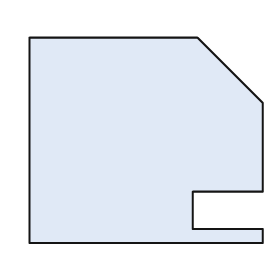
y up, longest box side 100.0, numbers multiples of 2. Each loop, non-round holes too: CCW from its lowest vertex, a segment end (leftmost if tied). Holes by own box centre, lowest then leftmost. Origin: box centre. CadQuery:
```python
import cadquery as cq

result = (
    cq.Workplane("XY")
    .moveTo(-50.0, -44.0)
    .lineTo(50.0, -44.0)
    .lineTo(50.0, -38.0)
    .lineTo(20.0, -38.0)
    .lineTo(20.0, -22.0)
    .lineTo(50.0, -22.0)
    .lineTo(50.0, 16.0)
    .lineTo(22.0, 44.0)
    .lineTo(-50.0, 44.0)
    .close()
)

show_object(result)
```